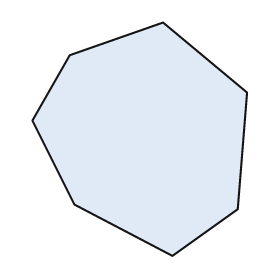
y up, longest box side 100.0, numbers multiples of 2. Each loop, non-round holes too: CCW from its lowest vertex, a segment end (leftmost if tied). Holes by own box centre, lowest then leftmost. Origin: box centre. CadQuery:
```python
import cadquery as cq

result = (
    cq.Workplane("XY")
    .moveTo(14.0, -50.0)
    .lineTo(42.0, -30.0)
    .lineTo(46.0, 20.0)
    .lineTo(10.0, 50.0)
    .lineTo(-30.0, 36.0)
    .lineTo(-46.0, 8.0)
    .lineTo(-28.0, -28.0)
    .close()
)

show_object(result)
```